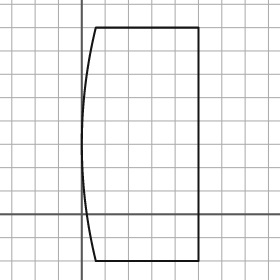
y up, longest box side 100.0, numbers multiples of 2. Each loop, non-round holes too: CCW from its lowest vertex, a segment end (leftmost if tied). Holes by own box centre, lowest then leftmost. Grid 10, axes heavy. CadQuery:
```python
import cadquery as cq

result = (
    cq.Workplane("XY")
    .moveTo(6.0, -20.0)
    .lineTo(50.0, -20.0)
    .lineTo(50.0, 80.0)
    .lineTo(6.0, 80.0)
    .threePointArc((0.0, 30.0), (6.0, -20.0))
    .close()
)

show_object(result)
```